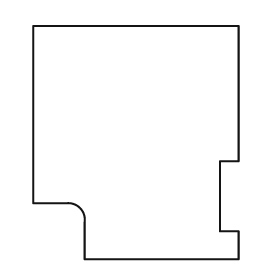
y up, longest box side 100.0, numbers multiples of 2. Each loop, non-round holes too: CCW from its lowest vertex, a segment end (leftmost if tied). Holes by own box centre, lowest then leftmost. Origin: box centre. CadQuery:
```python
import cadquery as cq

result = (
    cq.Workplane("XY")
    .moveTo(-22.0, -50.0)
    .lineTo(44.0, -50.0)
    .lineTo(44.0, -38.0)
    .lineTo(36.0, -38.0)
    .lineTo(36.0, -8.0)
    .lineTo(44.0, -8.0)
    .lineTo(44.0, 50.0)
    .lineTo(-44.0, 50.0)
    .lineTo(-44.0, -26.0)
    .lineTo(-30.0, -26.0)
    .threePointArc((-24.0, -28.0), (-22.0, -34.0))
    .close()
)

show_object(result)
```